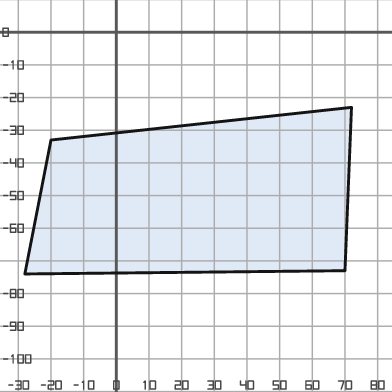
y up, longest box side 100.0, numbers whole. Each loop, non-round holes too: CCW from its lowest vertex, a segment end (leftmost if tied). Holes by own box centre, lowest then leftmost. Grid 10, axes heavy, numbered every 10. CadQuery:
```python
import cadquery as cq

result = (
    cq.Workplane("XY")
    .moveTo(-28.0, -74.0)
    .lineTo(70.0, -73.0)
    .lineTo(72.0, -23.0)
    .lineTo(-20.0, -33.0)
    .close()
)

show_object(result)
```